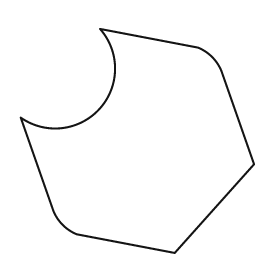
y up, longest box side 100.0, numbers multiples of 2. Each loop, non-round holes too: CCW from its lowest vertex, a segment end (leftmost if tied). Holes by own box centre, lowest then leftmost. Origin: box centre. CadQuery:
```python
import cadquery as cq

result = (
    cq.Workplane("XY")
    .moveTo(16.0, -48.0)
    .lineTo(50.0, -10.0)
    .lineTo(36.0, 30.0)
    .threePointArc((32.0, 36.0), (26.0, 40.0))
    .lineTo(-16.0, 48.0)
    .threePointArc((-16.0, 14.0), (-50.0, 10.0))
    .lineTo(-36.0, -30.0)
    .threePointArc((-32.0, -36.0), (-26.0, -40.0))
    .close()
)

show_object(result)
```